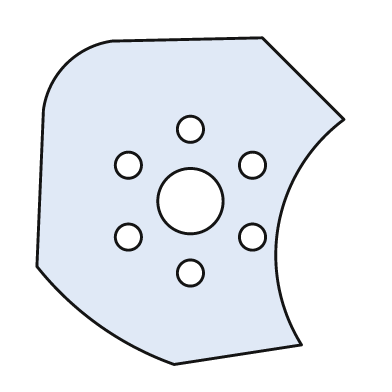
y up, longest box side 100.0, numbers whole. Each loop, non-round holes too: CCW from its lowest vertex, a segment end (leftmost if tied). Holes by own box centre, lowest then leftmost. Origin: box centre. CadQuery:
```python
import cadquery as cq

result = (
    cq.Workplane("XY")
    .moveTo(-5.0, -50.0)
    .lineTo(34.0, -44.0)
    .threePointArc((27.0, -7.0), (47.0, 25.0))
    .lineTo(22.0, 50.0)
    .lineTo(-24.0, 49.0)
    .threePointArc((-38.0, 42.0), (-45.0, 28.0))
    .lineTo(-47.0, -20.0)
    .threePointArc((-28.0, -38.0), (-5.0, -50.0))
    .close()
    .moveTo(0.0, -22.0)
    .circle(4.0)
    .moveTo(-19.0, -11.0)
    .circle(4.0)
    .moveTo(19.0, -11.0)
    .circle(4.0)
    .moveTo(0.0, 0.0)
    .circle(10.0)
    .moveTo(-19.0, 11.0)
    .circle(4.0)
    .moveTo(19.0, 11.0)
    .circle(4.0)
    .moveTo(0.0, 22.0)
    .circle(4.0)
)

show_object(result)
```